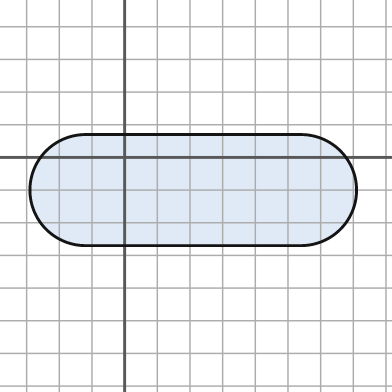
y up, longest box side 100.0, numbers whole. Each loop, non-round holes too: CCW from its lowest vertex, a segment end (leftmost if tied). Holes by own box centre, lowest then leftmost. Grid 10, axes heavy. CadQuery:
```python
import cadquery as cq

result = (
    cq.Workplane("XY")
    .moveTo(-12.0, -27.0)
    .lineTo(54.0, -27.0)
    .threePointArc((71.0, -10.0), (54.0, 7.0))
    .lineTo(-12.0, 7.0)
    .threePointArc((-29.0, -10.0), (-12.0, -27.0))
    .close()
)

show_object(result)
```